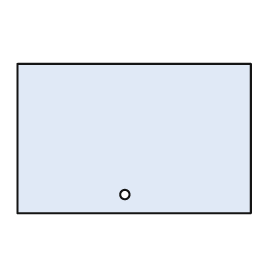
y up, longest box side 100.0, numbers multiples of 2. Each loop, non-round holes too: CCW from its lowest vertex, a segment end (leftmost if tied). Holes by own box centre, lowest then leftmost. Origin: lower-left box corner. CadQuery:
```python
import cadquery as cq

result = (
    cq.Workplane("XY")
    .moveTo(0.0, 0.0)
    .lineTo(100.0, 0.0)
    .lineTo(100.0, 64.0)
    .lineTo(0.0, 64.0)
    .close()
    .moveTo(46.0, 8.0)
    .circle(2.0)
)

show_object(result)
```